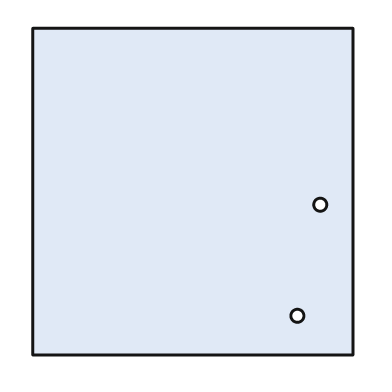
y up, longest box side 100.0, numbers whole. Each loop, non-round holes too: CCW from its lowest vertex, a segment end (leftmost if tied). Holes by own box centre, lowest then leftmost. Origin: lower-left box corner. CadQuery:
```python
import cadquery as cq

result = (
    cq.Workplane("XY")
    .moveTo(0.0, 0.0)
    .lineTo(98.0, 0.0)
    .lineTo(98.0, 100.0)
    .lineTo(0.0, 100.0)
    .close()
    .moveTo(81.0, 12.0)
    .circle(2.0)
    .moveTo(88.0, 46.0)
    .circle(2.0)
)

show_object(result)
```